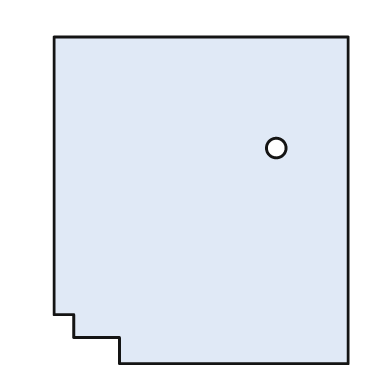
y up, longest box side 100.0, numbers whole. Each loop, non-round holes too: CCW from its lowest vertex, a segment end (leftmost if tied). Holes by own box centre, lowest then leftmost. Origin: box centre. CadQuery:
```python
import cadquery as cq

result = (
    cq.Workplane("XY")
    .moveTo(-25.0, -50.0)
    .lineTo(45.0, -50.0)
    .lineTo(45.0, 50.0)
    .lineTo(-45.0, 50.0)
    .lineTo(-45.0, -35.0)
    .lineTo(-39.0, -35.0)
    .lineTo(-39.0, -42.0)
    .lineTo(-25.0, -42.0)
    .close()
    .moveTo(23.0, 16.0)
    .circle(3.0)
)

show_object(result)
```